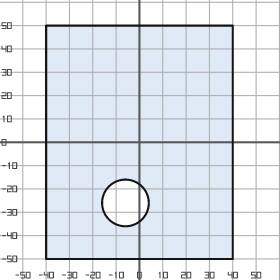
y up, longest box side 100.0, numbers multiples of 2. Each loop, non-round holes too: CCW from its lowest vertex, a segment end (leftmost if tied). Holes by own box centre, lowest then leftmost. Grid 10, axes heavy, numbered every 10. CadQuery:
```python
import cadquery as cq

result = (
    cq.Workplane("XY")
    .moveTo(-40.0, -50.0)
    .lineTo(40.0, -50.0)
    .lineTo(40.0, 50.0)
    .lineTo(-40.0, 50.0)
    .close()
    .moveTo(-6.0, -26.0)
    .circle(10.0)
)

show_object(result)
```